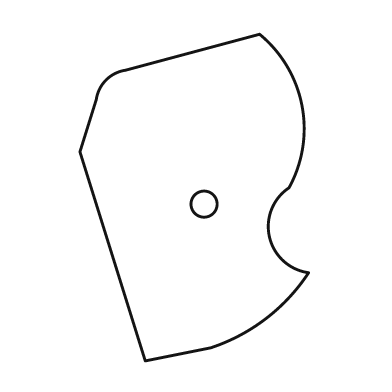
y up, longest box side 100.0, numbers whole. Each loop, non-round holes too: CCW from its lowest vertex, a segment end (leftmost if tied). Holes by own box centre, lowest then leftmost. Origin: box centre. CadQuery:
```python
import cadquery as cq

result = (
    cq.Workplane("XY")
    .moveTo(-15.0, -50.0)
    .lineTo(5.0, -46.0)
    .threePointArc((22.0, -37.0), (35.0, -23.0))
    .threePointArc((23.0, -12.0), (29.0, 3.0))
    .threePointArc((33.0, 28.0), (20.0, 50.0))
    .lineTo(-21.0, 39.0)
    .threePointArc((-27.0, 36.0), (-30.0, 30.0))
    .lineTo(-35.0, 14.0)
    .close()
    .moveTo(3.0, -2.0)
    .circle(4.0)
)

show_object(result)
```